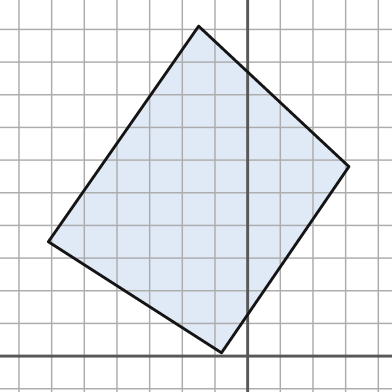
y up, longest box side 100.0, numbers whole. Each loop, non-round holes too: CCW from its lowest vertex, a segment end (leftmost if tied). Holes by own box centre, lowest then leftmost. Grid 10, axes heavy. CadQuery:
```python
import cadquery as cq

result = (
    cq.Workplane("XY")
    .moveTo(-8.0, 1.0)
    .lineTo(31.0, 58.0)
    .lineTo(-15.0, 101.0)
    .lineTo(-61.0, 35.0)
    .close()
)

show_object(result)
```